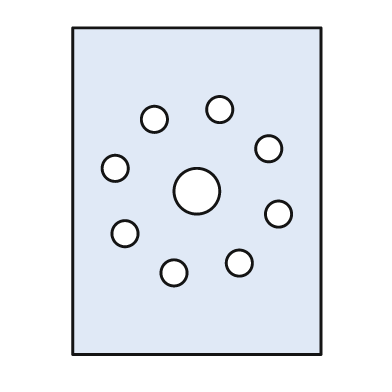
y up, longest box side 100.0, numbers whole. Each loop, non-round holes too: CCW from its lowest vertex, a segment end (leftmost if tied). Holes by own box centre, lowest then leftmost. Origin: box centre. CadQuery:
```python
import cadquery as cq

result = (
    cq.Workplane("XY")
    .moveTo(-38.0, -50.0)
    .lineTo(38.0, -50.0)
    .lineTo(38.0, 50.0)
    .lineTo(-38.0, 50.0)
    .close()
    .moveTo(-7.0, -25.0)
    .circle(4.0)
    .moveTo(13.0, -22.0)
    .circle(4.0)
    .moveTo(-22.0, -13.0)
    .circle(4.0)
    .moveTo(25.0, -7.0)
    .circle(4.0)
    .moveTo(0.0, 0.0)
    .circle(7.0)
    .moveTo(-25.0, 7.0)
    .circle(4.0)
    .moveTo(22.0, 13.0)
    .circle(4.0)
    .moveTo(-13.0, 22.0)
    .circle(4.0)
    .moveTo(7.0, 25.0)
    .circle(4.0)
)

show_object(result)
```